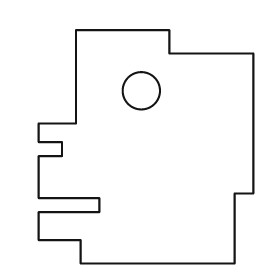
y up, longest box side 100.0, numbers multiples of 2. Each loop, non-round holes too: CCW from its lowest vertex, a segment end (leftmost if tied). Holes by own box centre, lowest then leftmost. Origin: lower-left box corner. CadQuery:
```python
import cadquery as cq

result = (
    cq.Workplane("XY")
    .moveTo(18.0, 0.0)
    .lineTo(84.0, 0.0)
    .lineTo(84.0, 30.0)
    .lineTo(92.0, 30.0)
    .lineTo(92.0, 90.0)
    .lineTo(56.0, 90.0)
    .lineTo(56.0, 100.0)
    .lineTo(16.0, 100.0)
    .lineTo(16.0, 60.0)
    .lineTo(0.0, 60.0)
    .lineTo(0.0, 52.0)
    .lineTo(10.0, 52.0)
    .lineTo(10.0, 46.0)
    .lineTo(0.0, 46.0)
    .lineTo(0.0, 28.0)
    .lineTo(26.0, 28.0)
    .lineTo(26.0, 22.0)
    .lineTo(0.0, 22.0)
    .lineTo(0.0, 10.0)
    .lineTo(18.0, 10.0)
    .close()
    .moveTo(44.0, 74.0)
    .circle(8.0)
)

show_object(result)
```